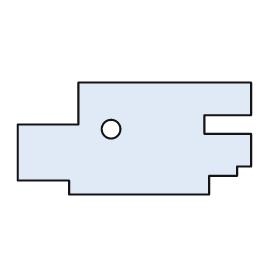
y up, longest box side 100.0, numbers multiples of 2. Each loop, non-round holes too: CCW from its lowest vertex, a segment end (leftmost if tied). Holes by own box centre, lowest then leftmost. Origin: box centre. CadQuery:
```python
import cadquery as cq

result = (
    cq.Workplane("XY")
    .moveTo(-28.0, -24.0)
    .lineTo(32.0, -24.0)
    .lineTo(32.0, -16.0)
    .lineTo(44.0, -16.0)
    .lineTo(44.0, -12.0)
    .lineTo(50.0, -12.0)
    .lineTo(50.0, 2.0)
    .lineTo(30.0, 2.0)
    .lineTo(30.0, 10.0)
    .lineTo(50.0, 10.0)
    .lineTo(50.0, 24.0)
    .lineTo(-24.0, 24.0)
    .lineTo(-24.0, 6.0)
    .lineTo(-50.0, 6.0)
    .lineTo(-50.0, -18.0)
    .lineTo(-28.0, -18.0)
    .close()
    .moveTo(-10.0, 4.0)
    .circle(4.0)
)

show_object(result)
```